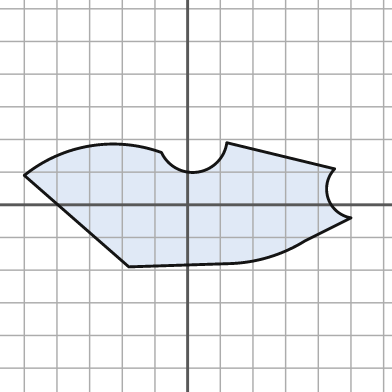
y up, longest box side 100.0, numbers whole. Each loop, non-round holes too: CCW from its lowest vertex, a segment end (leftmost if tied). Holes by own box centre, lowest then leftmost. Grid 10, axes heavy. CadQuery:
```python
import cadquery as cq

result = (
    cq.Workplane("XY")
    .moveTo(-18.0, -19.0)
    .lineTo(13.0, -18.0)
    .threePointArc((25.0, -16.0), (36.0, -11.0))
    .lineTo(50.0, -4.0)
    .threePointArc((43.0, 2.0), (45.0, 11.0))
    .lineTo(12.0, 19.0)
    .threePointArc((3.0, 10.0), (-8.0, 16.0))
    .threePointArc((-30.0, 18.0), (-50.0, 9.0))
    .close()
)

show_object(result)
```